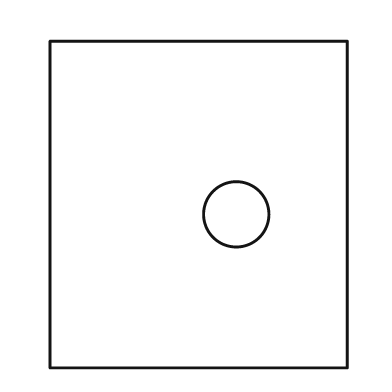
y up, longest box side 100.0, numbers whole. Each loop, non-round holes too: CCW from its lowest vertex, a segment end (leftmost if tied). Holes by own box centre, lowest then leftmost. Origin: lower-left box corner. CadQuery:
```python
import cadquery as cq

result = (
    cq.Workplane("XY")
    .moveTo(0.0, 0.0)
    .lineTo(91.0, 0.0)
    .lineTo(91.0, 100.0)
    .lineTo(0.0, 100.0)
    .close()
    .moveTo(57.0, 47.0)
    .circle(10.0)
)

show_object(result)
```